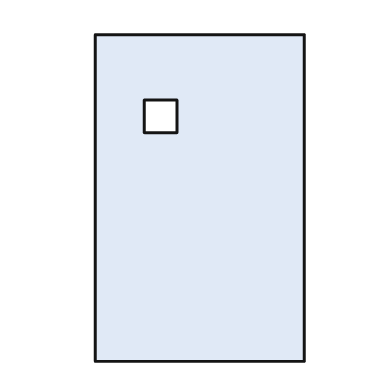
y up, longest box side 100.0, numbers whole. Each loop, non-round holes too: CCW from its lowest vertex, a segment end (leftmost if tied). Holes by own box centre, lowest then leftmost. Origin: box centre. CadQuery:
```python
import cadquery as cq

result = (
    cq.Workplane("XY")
    .moveTo(-32.0, -50.0)
    .lineTo(32.0, -50.0)
    .lineTo(32.0, 50.0)
    .lineTo(-32.0, 50.0)
    .close()
    .moveTo(-17.0, 20.0)
    .lineTo(-7.0, 20.0)
    .lineTo(-7.0, 30.0)
    .lineTo(-17.0, 30.0)
    .close()
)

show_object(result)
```